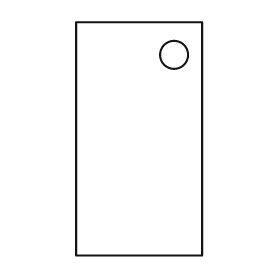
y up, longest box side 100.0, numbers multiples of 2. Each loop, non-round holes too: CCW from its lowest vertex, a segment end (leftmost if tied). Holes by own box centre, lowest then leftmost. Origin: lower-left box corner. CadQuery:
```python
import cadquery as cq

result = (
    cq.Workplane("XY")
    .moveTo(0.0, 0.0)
    .lineTo(54.0, 0.0)
    .lineTo(54.0, 100.0)
    .lineTo(0.0, 100.0)
    .close()
    .moveTo(42.0, 86.0)
    .circle(6.0)
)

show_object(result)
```